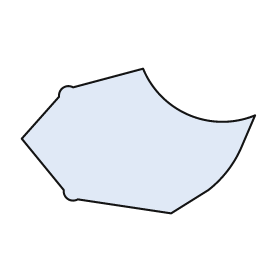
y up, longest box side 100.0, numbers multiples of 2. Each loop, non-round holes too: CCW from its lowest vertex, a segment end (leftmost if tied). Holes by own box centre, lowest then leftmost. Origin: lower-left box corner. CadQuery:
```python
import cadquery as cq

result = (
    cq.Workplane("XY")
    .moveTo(64.0, 0.0)
    .lineTo(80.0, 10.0)
    .threePointArc((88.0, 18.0), (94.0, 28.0))
    .lineTo(100.0, 42.0)
    .threePointArc((72.0, 42.0), (52.0, 62.0))
    .lineTo(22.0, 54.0)
    .threePointArc((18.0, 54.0), (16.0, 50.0))
    .lineTo(0.0, 32.0)
    .lineTo(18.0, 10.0)
    .threePointArc((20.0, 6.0), (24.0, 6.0))
    .close()
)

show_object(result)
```